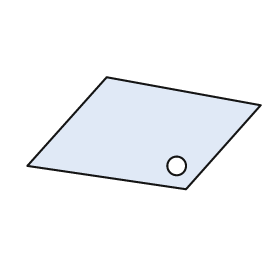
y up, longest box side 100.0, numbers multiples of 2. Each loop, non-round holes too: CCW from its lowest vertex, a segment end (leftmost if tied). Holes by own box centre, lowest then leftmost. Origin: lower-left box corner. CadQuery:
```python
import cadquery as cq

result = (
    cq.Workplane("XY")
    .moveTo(68.0, 0.0)
    .lineTo(100.0, 36.0)
    .lineTo(34.0, 48.0)
    .lineTo(0.0, 10.0)
    .close()
    .moveTo(64.0, 10.0)
    .circle(4.0)
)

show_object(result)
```